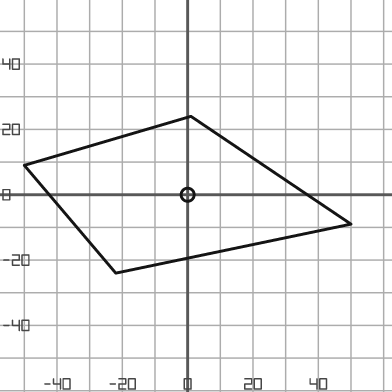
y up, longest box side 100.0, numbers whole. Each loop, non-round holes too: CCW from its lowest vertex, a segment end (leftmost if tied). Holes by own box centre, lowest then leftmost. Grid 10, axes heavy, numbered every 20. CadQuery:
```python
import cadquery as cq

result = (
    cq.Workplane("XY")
    .moveTo(-22.0, -24.0)
    .lineTo(50.0, -9.0)
    .lineTo(1.0, 24.0)
    .lineTo(-50.0, 9.0)
    .close()
    .moveTo(0.0, 0.0)
    .circle(2.0)
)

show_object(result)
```